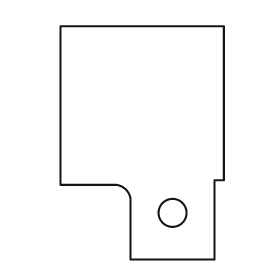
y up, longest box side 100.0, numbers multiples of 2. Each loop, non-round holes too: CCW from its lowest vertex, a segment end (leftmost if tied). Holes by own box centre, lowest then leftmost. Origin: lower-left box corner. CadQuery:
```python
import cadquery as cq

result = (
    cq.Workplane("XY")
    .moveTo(30.0, 0.0)
    .lineTo(66.0, 0.0)
    .lineTo(66.0, 34.0)
    .lineTo(70.0, 34.0)
    .lineTo(70.0, 100.0)
    .lineTo(0.0, 100.0)
    .lineTo(0.0, 32.0)
    .lineTo(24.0, 32.0)
    .threePointArc((28.0, 30.0), (30.0, 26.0))
    .close()
    .moveTo(48.0, 20.0)
    .circle(6.0)
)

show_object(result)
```